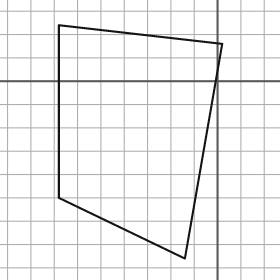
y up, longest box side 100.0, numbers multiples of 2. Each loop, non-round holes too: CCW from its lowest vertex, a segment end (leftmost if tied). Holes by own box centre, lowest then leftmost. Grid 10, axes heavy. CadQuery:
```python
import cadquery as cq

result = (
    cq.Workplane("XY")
    .moveTo(-14.0, -76.0)
    .lineTo(2.0, 16.0)
    .lineTo(-68.0, 24.0)
    .lineTo(-68.0, -50.0)
    .close()
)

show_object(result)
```